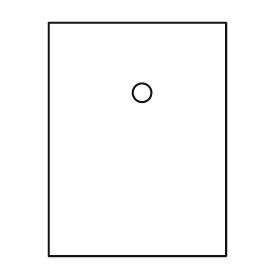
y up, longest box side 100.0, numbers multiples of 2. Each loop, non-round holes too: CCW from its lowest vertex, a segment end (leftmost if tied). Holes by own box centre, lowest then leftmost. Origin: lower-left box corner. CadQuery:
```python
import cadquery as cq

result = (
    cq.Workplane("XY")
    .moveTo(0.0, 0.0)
    .lineTo(76.0, 0.0)
    .lineTo(76.0, 100.0)
    .lineTo(0.0, 100.0)
    .close()
    .moveTo(40.0, 70.0)
    .circle(4.0)
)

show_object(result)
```